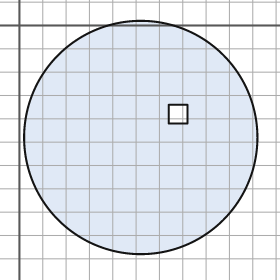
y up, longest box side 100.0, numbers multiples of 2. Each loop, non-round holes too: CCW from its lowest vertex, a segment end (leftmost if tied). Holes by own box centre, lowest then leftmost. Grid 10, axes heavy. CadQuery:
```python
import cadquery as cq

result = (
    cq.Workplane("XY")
    .moveTo(52.0, -48.0)
    .circle(50.0)
    .moveTo(64.0, -42.0)
    .lineTo(72.0, -42.0)
    .lineTo(72.0, -34.0)
    .lineTo(64.0, -34.0)
    .close()
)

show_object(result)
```